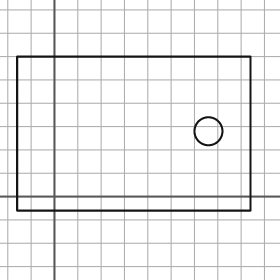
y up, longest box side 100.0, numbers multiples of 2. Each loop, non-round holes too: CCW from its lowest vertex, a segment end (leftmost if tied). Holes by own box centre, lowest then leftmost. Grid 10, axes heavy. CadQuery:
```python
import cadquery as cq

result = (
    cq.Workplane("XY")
    .moveTo(-16.0, -6.0)
    .lineTo(84.0, -6.0)
    .lineTo(84.0, 60.0)
    .lineTo(-16.0, 60.0)
    .close()
    .moveTo(66.0, 28.0)
    .circle(6.0)
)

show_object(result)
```